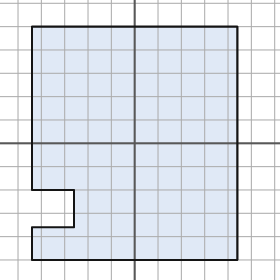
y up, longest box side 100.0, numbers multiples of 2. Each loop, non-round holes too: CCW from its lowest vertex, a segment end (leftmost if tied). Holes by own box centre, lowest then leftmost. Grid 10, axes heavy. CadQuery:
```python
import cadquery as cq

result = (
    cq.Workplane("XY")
    .moveTo(-44.0, -50.0)
    .lineTo(44.0, -50.0)
    .lineTo(44.0, 50.0)
    .lineTo(-44.0, 50.0)
    .lineTo(-44.0, -20.0)
    .lineTo(-26.0, -20.0)
    .lineTo(-26.0, -36.0)
    .lineTo(-44.0, -36.0)
    .close()
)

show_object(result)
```